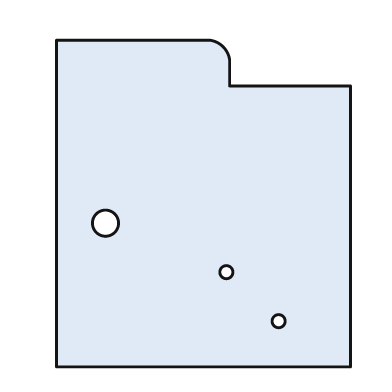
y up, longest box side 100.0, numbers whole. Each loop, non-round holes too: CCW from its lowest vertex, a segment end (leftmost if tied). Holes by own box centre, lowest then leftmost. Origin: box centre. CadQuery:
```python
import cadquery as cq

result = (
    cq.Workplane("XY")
    .moveTo(-45.0, -50.0)
    .lineTo(45.0, -50.0)
    .lineTo(45.0, 36.0)
    .lineTo(8.0, 36.0)
    .lineTo(8.0, 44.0)
    .threePointArc((6.0, 48.0), (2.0, 50.0))
    .lineTo(-45.0, 50.0)
    .close()
    .moveTo(23.0, -36.0)
    .circle(2.0)
    .moveTo(7.0, -21.0)
    .circle(2.0)
    .moveTo(-30.0, -6.0)
    .circle(4.0)
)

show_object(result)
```